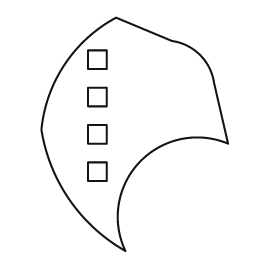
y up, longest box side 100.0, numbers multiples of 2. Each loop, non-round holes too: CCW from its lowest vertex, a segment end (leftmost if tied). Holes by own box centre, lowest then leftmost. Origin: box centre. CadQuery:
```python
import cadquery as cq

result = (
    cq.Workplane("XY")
    .moveTo(-4.0, -50.0)
    .threePointArc((2.0, -12.0), (40.0, -4.0))
    .lineTo(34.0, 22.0)
    .threePointArc((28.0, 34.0), (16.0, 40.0))
    .lineTo(-8.0, 50.0)
    .threePointArc((-30.0, 30.0), (-40.0, 2.0))
    .threePointArc((-28.0, -28.0), (-4.0, -50.0))
    .close()
    .moveTo(-20.0, -20.0)
    .lineTo(-12.0, -20.0)
    .lineTo(-12.0, -12.0)
    .lineTo(-20.0, -12.0)
    .close()
    .moveTo(-20.0, -4.0)
    .lineTo(-12.0, -4.0)
    .lineTo(-12.0, 4.0)
    .lineTo(-20.0, 4.0)
    .close()
    .moveTo(-20.0, 12.0)
    .lineTo(-12.0, 12.0)
    .lineTo(-12.0, 20.0)
    .lineTo(-20.0, 20.0)
    .close()
    .moveTo(-20.0, 28.0)
    .lineTo(-12.0, 28.0)
    .lineTo(-12.0, 36.0)
    .lineTo(-20.0, 36.0)
    .close()
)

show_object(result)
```